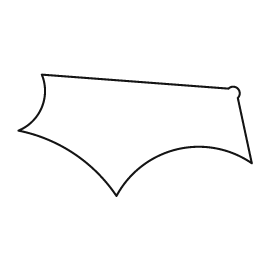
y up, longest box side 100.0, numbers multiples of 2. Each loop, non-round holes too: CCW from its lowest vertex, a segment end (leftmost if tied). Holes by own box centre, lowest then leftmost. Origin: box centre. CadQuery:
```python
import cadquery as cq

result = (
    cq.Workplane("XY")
    .moveTo(-8.0, -26.0)
    .threePointArc((18.0, -6.0), (50.0, -12.0))
    .lineTo(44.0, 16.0)
    .threePointArc((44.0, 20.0), (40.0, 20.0))
    .lineTo(-40.0, 26.0)
    .threePointArc((-40.0, 12.0), (-50.0, 2.0))
    .threePointArc((-26.0, -8.0), (-8.0, -26.0))
    .close()
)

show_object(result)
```